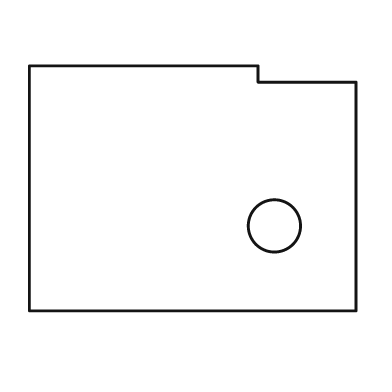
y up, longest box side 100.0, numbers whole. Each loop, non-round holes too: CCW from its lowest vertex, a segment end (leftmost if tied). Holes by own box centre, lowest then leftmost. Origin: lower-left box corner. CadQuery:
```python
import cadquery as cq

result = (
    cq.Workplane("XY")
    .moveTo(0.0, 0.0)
    .lineTo(100.0, 0.0)
    .lineTo(100.0, 70.0)
    .lineTo(70.0, 70.0)
    .lineTo(70.0, 75.0)
    .lineTo(0.0, 75.0)
    .close()
    .moveTo(75.0, 26.0)
    .circle(8.0)
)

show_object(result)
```